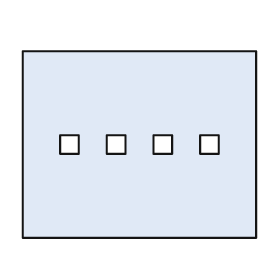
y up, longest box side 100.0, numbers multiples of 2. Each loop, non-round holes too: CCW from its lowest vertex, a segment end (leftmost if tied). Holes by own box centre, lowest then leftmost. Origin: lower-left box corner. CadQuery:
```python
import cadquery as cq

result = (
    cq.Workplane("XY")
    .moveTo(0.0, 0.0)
    .lineTo(100.0, 0.0)
    .lineTo(100.0, 80.0)
    .lineTo(0.0, 80.0)
    .close()
    .moveTo(16.0, 36.0)
    .lineTo(24.0, 36.0)
    .lineTo(24.0, 44.0)
    .lineTo(16.0, 44.0)
    .close()
    .moveTo(36.0, 36.0)
    .lineTo(44.0, 36.0)
    .lineTo(44.0, 44.0)
    .lineTo(36.0, 44.0)
    .close()
    .moveTo(56.0, 36.0)
    .lineTo(64.0, 36.0)
    .lineTo(64.0, 44.0)
    .lineTo(56.0, 44.0)
    .close()
    .moveTo(76.0, 36.0)
    .lineTo(84.0, 36.0)
    .lineTo(84.0, 44.0)
    .lineTo(76.0, 44.0)
    .close()
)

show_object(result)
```